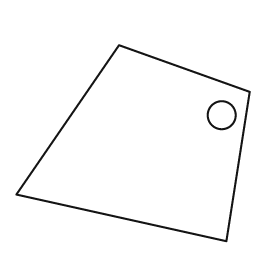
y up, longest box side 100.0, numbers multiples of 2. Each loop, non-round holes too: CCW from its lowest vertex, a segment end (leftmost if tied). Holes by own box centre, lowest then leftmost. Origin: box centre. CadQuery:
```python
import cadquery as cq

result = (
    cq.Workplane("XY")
    .moveTo(40.0, -42.0)
    .lineTo(50.0, 22.0)
    .lineTo(-6.0, 42.0)
    .lineTo(-50.0, -22.0)
    .close()
    .moveTo(38.0, 12.0)
    .circle(6.0)
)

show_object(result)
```